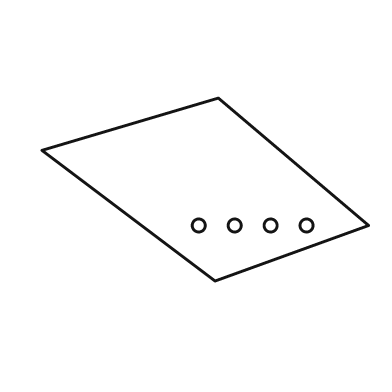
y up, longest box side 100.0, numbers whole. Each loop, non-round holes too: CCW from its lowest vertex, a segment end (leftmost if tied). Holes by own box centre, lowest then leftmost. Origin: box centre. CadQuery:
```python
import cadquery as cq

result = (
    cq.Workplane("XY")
    .moveTo(3.0, -28.0)
    .lineTo(50.0, -11.0)
    .lineTo(4.0, 28.0)
    .lineTo(-50.0, 12.0)
    .close()
    .moveTo(-2.0, -11.0)
    .circle(2.0)
    .moveTo(9.0, -11.0)
    .circle(2.0)
    .moveTo(20.0, -11.0)
    .circle(2.0)
    .moveTo(31.0, -11.0)
    .circle(2.0)
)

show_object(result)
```